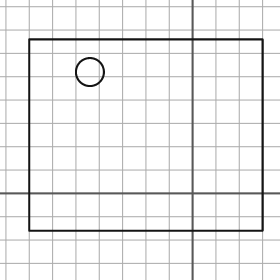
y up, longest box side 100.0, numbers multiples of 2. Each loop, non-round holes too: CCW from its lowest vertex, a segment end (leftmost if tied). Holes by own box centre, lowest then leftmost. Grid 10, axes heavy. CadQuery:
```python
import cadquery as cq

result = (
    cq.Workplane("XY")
    .moveTo(-70.0, -16.0)
    .lineTo(30.0, -16.0)
    .lineTo(30.0, 66.0)
    .lineTo(-70.0, 66.0)
    .close()
    .moveTo(-44.0, 52.0)
    .circle(6.0)
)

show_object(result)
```